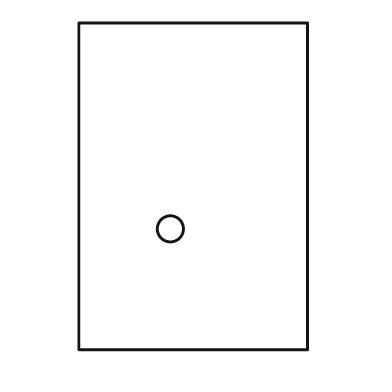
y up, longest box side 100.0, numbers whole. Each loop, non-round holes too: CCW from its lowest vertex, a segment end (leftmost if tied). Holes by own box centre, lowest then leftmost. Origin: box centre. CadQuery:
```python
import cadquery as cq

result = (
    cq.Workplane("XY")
    .moveTo(-35.0, -50.0)
    .lineTo(35.0, -50.0)
    .lineTo(35.0, 50.0)
    .lineTo(-35.0, 50.0)
    .close()
    .moveTo(-7.0, -13.0)
    .circle(4.0)
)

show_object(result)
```